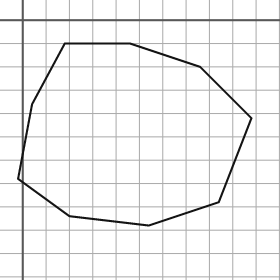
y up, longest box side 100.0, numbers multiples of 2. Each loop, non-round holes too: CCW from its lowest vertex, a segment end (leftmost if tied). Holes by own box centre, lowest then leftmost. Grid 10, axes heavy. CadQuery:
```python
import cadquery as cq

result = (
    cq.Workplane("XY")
    .moveTo(54.0, -88.0)
    .lineTo(84.0, -78.0)
    .lineTo(98.0, -42.0)
    .lineTo(76.0, -20.0)
    .lineTo(46.0, -10.0)
    .lineTo(18.0, -10.0)
    .lineTo(4.0, -36.0)
    .lineTo(-2.0, -68.0)
    .lineTo(20.0, -84.0)
    .close()
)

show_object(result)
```